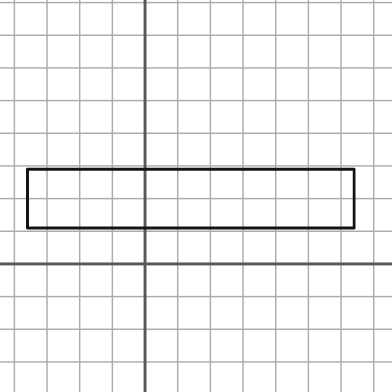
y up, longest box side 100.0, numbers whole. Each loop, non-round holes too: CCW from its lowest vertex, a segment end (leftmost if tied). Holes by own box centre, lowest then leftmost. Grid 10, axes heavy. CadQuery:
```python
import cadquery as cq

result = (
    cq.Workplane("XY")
    .moveTo(-36.0, 11.0)
    .lineTo(64.0, 11.0)
    .lineTo(64.0, 29.0)
    .lineTo(-36.0, 29.0)
    .close()
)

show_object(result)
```